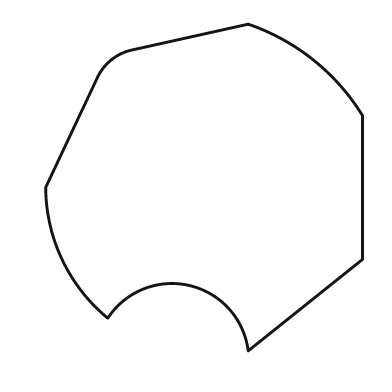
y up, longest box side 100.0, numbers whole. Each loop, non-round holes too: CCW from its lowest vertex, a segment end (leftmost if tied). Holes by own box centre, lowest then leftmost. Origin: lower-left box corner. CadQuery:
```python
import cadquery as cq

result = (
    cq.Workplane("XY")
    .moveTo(62.0, 0.0)
    .lineTo(97.0, 28.0)
    .lineTo(97.0, 72.0)
    .threePointArc((82.0, 89.0), (62.0, 100.0))
    .lineTo(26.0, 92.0)
    .threePointArc((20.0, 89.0), (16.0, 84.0))
    .lineTo(0.0, 50.0)
    .threePointArc((5.0, 28.0), (19.0, 10.0))
    .threePointArc((44.0, 20.0), (62.0, 0.0))
    .close()
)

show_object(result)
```